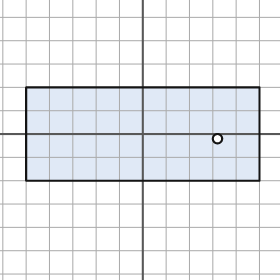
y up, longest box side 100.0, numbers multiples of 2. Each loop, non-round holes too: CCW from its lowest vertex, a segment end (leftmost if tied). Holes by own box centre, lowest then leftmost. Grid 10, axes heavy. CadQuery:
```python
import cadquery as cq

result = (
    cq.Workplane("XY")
    .moveTo(-50.0, -20.0)
    .lineTo(50.0, -20.0)
    .lineTo(50.0, 20.0)
    .lineTo(-50.0, 20.0)
    .close()
    .moveTo(32.0, -2.0)
    .circle(2.0)
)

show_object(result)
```